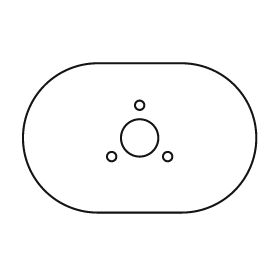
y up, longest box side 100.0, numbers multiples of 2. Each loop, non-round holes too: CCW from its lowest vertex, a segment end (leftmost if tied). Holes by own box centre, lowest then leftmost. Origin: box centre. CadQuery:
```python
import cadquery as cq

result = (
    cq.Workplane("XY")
    .moveTo(-18.0, -32.0)
    .lineTo(18.0, -32.0)
    .threePointArc((50.0, 0.0), (18.0, 32.0))
    .lineTo(-18.0, 32.0)
    .threePointArc((-50.0, 0.0), (-18.0, -32.0))
    .close()
    .moveTo(-12.0, -8.0)
    .circle(2.0)
    .moveTo(12.0, -8.0)
    .circle(2.0)
    .moveTo(0.0, 0.0)
    .circle(8.0)
    .moveTo(0.0, 14.0)
    .circle(2.0)
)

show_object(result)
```